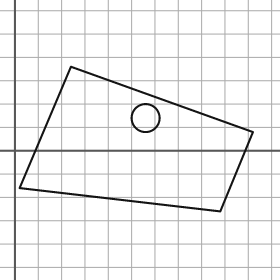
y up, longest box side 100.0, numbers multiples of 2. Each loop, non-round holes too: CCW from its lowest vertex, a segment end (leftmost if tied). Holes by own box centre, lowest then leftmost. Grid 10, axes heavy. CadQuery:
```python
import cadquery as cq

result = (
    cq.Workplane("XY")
    .moveTo(88.0, -26.0)
    .lineTo(102.0, 8.0)
    .lineTo(24.0, 36.0)
    .lineTo(2.0, -16.0)
    .close()
    .moveTo(56.0, 14.0)
    .circle(6.0)
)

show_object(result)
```